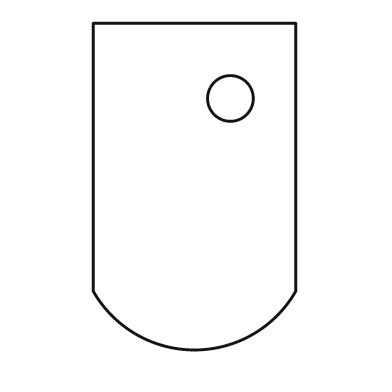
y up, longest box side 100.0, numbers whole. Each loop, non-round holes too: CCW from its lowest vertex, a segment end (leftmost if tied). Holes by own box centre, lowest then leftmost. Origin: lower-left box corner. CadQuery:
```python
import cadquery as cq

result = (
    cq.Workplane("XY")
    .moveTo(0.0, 18.0)
    .threePointArc((31.0, 0.0), (62.0, 18.0))
    .lineTo(62.0, 100.0)
    .lineTo(0.0, 100.0)
    .close()
    .moveTo(42.0, 77.0)
    .circle(7.0)
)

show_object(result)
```